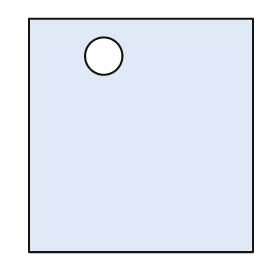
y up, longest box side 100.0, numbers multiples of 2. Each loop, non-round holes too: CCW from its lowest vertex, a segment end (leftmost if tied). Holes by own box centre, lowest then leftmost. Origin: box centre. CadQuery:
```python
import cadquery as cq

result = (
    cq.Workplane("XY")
    .moveTo(-48.0, -50.0)
    .lineTo(48.0, -50.0)
    .lineTo(48.0, 50.0)
    .lineTo(-48.0, 50.0)
    .close()
    .moveTo(-16.0, 34.0)
    .circle(8.0)
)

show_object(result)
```